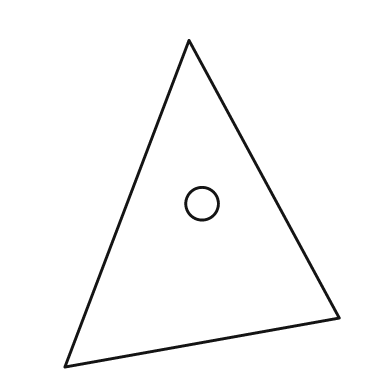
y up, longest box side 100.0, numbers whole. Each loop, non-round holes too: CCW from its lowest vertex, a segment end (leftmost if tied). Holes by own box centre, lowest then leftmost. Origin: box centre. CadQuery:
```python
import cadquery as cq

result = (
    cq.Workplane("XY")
    .moveTo(-42.0, -50.0)
    .lineTo(42.0, -35.0)
    .lineTo(-4.0, 50.0)
    .close()
    .moveTo(0.0, 0.0)
    .circle(5.0)
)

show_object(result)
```